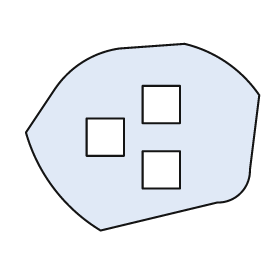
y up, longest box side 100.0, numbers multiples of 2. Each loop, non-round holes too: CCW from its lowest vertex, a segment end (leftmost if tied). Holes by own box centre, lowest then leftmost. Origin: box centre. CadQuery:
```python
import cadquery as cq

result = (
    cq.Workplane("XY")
    .moveTo(-18.0, -40.0)
    .lineTo(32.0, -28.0)
    .threePointArc((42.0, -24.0), (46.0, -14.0))
    .lineTo(50.0, 18.0)
    .threePointArc((36.0, 32.0), (18.0, 40.0))
    .lineTo(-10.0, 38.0)
    .threePointArc((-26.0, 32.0), (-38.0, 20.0))
    .lineTo(-50.0, 2.0)
    .threePointArc((-38.0, -22.0), (-18.0, -40.0))
    .close()
    .moveTo(0.0, -22.0)
    .lineTo(16.0, -22.0)
    .lineTo(16.0, -6.0)
    .lineTo(0.0, -6.0)
    .close()
    .moveTo(-24.0, -8.0)
    .lineTo(-8.0, -8.0)
    .lineTo(-8.0, 8.0)
    .lineTo(-24.0, 8.0)
    .close()
    .moveTo(0.0, 6.0)
    .lineTo(16.0, 6.0)
    .lineTo(16.0, 22.0)
    .lineTo(0.0, 22.0)
    .close()
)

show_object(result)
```